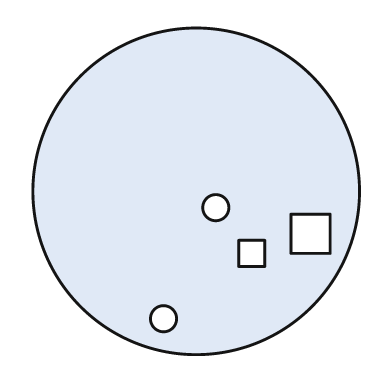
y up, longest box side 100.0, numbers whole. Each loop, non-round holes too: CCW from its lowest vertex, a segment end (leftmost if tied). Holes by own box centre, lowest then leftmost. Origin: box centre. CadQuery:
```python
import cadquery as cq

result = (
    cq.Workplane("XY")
    .moveTo(0.0, 0.0)
    .circle(50.0)
    .moveTo(-10.0, -39.0)
    .circle(4.0)
    .moveTo(13.0, -23.0)
    .lineTo(21.0, -23.0)
    .lineTo(21.0, -15.0)
    .lineTo(13.0, -15.0)
    .close()
    .moveTo(29.0, -19.0)
    .lineTo(41.0, -19.0)
    .lineTo(41.0, -7.0)
    .lineTo(29.0, -7.0)
    .close()
    .moveTo(6.0, -5.0)
    .circle(4.0)
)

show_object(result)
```